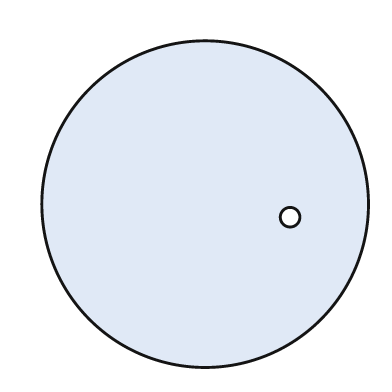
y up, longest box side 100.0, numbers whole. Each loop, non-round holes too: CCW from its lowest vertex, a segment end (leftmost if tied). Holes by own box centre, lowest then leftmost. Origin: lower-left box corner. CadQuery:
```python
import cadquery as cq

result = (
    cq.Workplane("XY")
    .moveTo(50.0, 50.0)
    .circle(50.0)
    .moveTo(76.0, 46.0)
    .circle(3.0)
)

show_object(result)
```